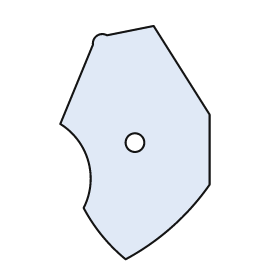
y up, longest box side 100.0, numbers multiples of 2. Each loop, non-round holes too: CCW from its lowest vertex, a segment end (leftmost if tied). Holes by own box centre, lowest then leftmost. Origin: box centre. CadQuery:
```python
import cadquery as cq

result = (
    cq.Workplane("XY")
    .moveTo(-4.0, -50.0)
    .threePointArc((16.0, -36.0), (32.0, -18.0))
    .lineTo(32.0, 12.0)
    .lineTo(8.0, 50.0)
    .lineTo(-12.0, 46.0)
    .threePointArc((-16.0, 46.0), (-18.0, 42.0))
    .lineTo(-32.0, 8.0)
    .threePointArc((-20.0, -8.0), (-22.0, -28.0))
    .threePointArc((-14.0, -40.0), (-4.0, -50.0))
    .close()
    .moveTo(0.0, 0.0)
    .circle(4.0)
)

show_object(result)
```